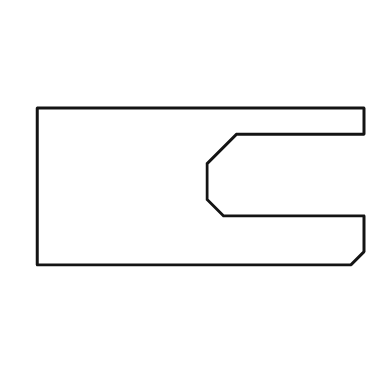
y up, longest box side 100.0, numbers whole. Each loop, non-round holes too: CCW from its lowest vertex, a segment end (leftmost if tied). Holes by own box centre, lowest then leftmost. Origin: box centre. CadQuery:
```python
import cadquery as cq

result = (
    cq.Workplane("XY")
    .moveTo(-50.0, -24.0)
    .lineTo(46.0, -24.0)
    .lineTo(50.0, -20.0)
    .lineTo(50.0, -9.0)
    .lineTo(7.0, -9.0)
    .lineTo(2.0, -4.0)
    .lineTo(2.0, 7.0)
    .lineTo(11.0, 16.0)
    .lineTo(50.0, 16.0)
    .lineTo(50.0, 24.0)
    .lineTo(-50.0, 24.0)
    .close()
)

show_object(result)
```